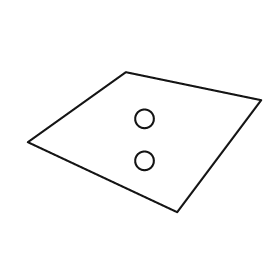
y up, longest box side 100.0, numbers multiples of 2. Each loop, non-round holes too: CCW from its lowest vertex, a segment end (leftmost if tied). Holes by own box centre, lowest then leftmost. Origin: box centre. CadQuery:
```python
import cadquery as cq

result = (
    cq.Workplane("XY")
    .moveTo(14.0, -30.0)
    .lineTo(50.0, 18.0)
    .lineTo(-8.0, 30.0)
    .lineTo(-50.0, 0.0)
    .close()
    .moveTo(0.0, -8.0)
    .circle(4.0)
    .moveTo(0.0, 10.0)
    .circle(4.0)
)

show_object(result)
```